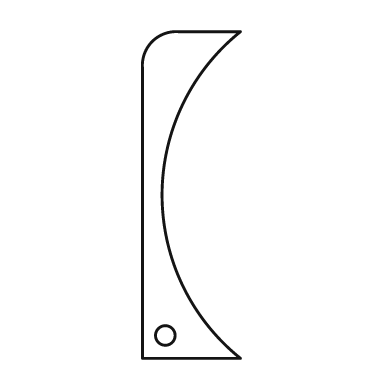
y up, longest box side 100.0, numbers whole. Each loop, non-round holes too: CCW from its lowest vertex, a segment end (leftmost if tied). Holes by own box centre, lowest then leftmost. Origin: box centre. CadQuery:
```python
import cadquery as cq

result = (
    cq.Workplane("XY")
    .moveTo(-15.0, -50.0)
    .lineTo(15.0, -50.0)
    .threePointArc((-9.0, 0.0), (15.0, 50.0))
    .lineTo(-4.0, 50.0)
    .threePointArc((-12.0, 47.0), (-15.0, 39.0))
    .close()
    .moveTo(-8.0, -43.0)
    .circle(3.0)
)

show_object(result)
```